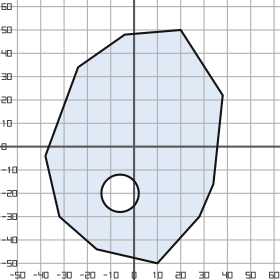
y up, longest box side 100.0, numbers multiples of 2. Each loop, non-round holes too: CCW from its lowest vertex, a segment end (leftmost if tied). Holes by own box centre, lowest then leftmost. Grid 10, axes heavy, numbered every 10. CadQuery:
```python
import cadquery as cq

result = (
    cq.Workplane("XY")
    .moveTo(10.0, -50.0)
    .lineTo(28.0, -30.0)
    .lineTo(34.0, -16.0)
    .lineTo(38.0, 22.0)
    .lineTo(20.0, 50.0)
    .lineTo(-4.0, 48.0)
    .lineTo(-24.0, 34.0)
    .lineTo(-38.0, -4.0)
    .lineTo(-32.0, -30.0)
    .lineTo(-16.0, -44.0)
    .close()
    .moveTo(-6.0, -20.0)
    .circle(8.0)
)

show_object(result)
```